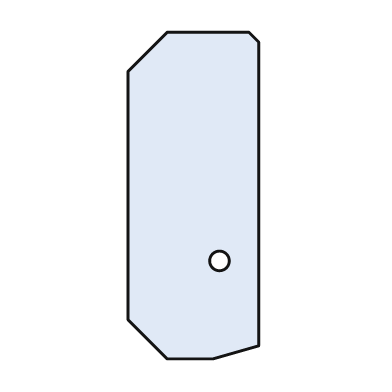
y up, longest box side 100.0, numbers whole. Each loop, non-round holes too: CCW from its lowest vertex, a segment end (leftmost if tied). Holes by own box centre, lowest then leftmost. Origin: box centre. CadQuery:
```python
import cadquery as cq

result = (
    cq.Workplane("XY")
    .moveTo(-8.0, -50.0)
    .lineTo(6.0, -50.0)
    .lineTo(20.0, -46.0)
    .lineTo(20.0, 47.0)
    .lineTo(17.0, 50.0)
    .lineTo(-8.0, 50.0)
    .lineTo(-20.0, 38.0)
    .lineTo(-20.0, -38.0)
    .close()
    .moveTo(8.0, -20.0)
    .circle(3.0)
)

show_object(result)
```